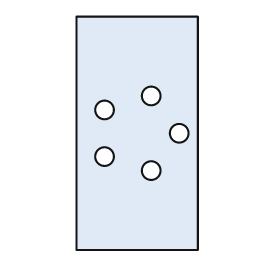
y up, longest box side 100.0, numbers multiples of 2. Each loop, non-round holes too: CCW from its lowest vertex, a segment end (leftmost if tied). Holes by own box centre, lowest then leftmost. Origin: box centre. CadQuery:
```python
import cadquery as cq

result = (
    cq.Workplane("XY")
    .moveTo(-26.0, -50.0)
    .lineTo(26.0, -50.0)
    .lineTo(26.0, 50.0)
    .lineTo(-26.0, 50.0)
    .close()
    .moveTo(6.0, -16.0)
    .circle(4.0)
    .moveTo(-14.0, -10.0)
    .circle(4.0)
    .moveTo(18.0, 0.0)
    .circle(4.0)
    .moveTo(-14.0, 10.0)
    .circle(4.0)
    .moveTo(6.0, 16.0)
    .circle(4.0)
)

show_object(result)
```